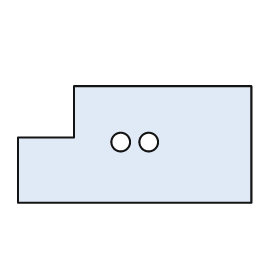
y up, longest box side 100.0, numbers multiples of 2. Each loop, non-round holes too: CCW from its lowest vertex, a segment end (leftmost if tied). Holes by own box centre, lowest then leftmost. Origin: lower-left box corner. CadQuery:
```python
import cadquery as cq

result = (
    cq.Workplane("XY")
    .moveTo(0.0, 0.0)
    .lineTo(100.0, 0.0)
    .lineTo(100.0, 50.0)
    .lineTo(24.0, 50.0)
    .lineTo(24.0, 28.0)
    .lineTo(0.0, 28.0)
    .close()
    .moveTo(44.0, 26.0)
    .circle(4.0)
    .moveTo(56.0, 26.0)
    .circle(4.0)
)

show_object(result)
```